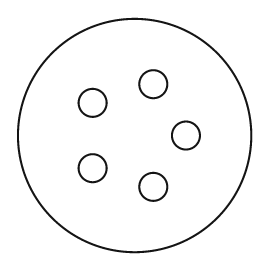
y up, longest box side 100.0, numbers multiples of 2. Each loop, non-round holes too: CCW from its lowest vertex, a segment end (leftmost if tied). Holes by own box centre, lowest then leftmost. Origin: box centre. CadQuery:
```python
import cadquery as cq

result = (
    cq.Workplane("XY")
    .moveTo(0.0, 0.0)
    .circle(50.0)
    .moveTo(8.0, -22.0)
    .circle(6.0)
    .moveTo(-18.0, -14.0)
    .circle(6.0)
    .moveTo(22.0, 0.0)
    .circle(6.0)
    .moveTo(-18.0, 14.0)
    .circle(6.0)
    .moveTo(8.0, 22.0)
    .circle(6.0)
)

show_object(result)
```